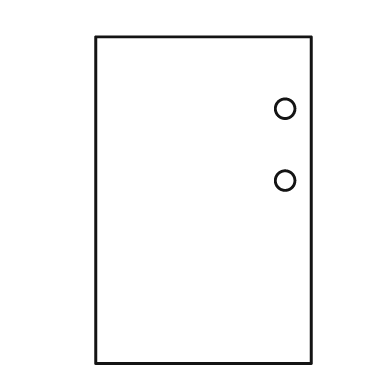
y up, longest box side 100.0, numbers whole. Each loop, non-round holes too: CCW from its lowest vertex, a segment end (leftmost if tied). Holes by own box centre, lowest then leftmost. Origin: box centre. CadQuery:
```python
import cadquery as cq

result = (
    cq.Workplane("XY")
    .moveTo(-33.0, -50.0)
    .lineTo(33.0, -50.0)
    .lineTo(33.0, 50.0)
    .lineTo(-33.0, 50.0)
    .close()
    .moveTo(25.0, 6.0)
    .circle(3.0)
    .moveTo(25.0, 28.0)
    .circle(3.0)
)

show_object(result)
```